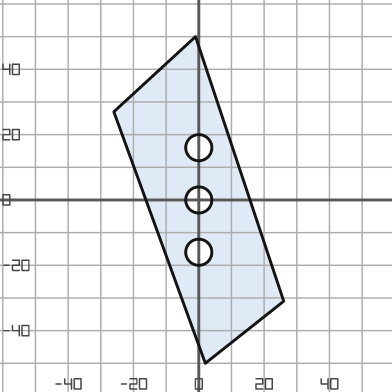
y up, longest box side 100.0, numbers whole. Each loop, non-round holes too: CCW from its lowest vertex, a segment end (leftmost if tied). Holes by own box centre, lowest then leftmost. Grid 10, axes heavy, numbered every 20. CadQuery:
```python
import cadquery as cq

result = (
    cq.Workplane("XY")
    .moveTo(2.0, -50.0)
    .lineTo(26.0, -31.0)
    .lineTo(-1.0, 50.0)
    .lineTo(-26.0, 27.0)
    .close()
    .moveTo(0.0, -16.0)
    .circle(4.0)
    .moveTo(0.0, 0.0)
    .circle(4.0)
    .moveTo(0.0, 16.0)
    .circle(4.0)
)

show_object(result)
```